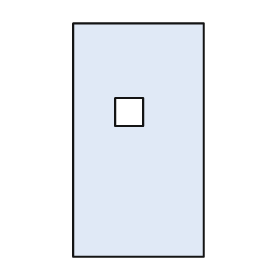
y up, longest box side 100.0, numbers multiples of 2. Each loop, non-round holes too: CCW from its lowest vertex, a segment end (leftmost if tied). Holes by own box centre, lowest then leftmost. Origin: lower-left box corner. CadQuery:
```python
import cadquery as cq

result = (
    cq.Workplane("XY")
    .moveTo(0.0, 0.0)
    .lineTo(56.0, 0.0)
    .lineTo(56.0, 100.0)
    .lineTo(0.0, 100.0)
    .close()
    .moveTo(18.0, 56.0)
    .lineTo(30.0, 56.0)
    .lineTo(30.0, 68.0)
    .lineTo(18.0, 68.0)
    .close()
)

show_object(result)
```